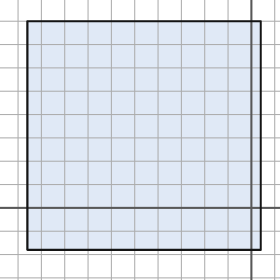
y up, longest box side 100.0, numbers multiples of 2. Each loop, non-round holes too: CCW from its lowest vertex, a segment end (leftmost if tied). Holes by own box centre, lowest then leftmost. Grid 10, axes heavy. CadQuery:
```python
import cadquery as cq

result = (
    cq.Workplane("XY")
    .moveTo(-96.0, -18.0)
    .lineTo(4.0, -18.0)
    .lineTo(4.0, 80.0)
    .lineTo(-96.0, 80.0)
    .close()
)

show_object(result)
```